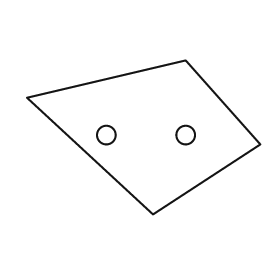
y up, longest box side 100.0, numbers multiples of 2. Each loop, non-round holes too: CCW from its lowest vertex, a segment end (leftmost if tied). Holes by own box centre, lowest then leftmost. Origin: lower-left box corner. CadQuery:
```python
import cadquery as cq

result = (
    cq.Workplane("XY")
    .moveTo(54.0, 0.0)
    .lineTo(100.0, 30.0)
    .lineTo(68.0, 66.0)
    .lineTo(0.0, 50.0)
    .close()
    .moveTo(34.0, 34.0)
    .circle(4.0)
    .moveTo(68.0, 34.0)
    .circle(4.0)
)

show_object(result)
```